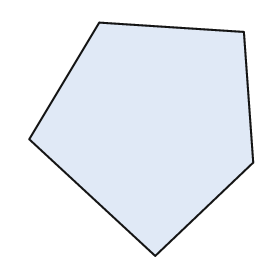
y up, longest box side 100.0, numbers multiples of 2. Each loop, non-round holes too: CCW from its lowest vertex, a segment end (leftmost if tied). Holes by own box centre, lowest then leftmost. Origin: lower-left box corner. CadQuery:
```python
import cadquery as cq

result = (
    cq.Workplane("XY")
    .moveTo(54.0, 0.0)
    .lineTo(96.0, 40.0)
    .lineTo(92.0, 96.0)
    .lineTo(30.0, 100.0)
    .lineTo(0.0, 50.0)
    .close()
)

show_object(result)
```